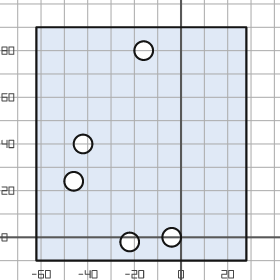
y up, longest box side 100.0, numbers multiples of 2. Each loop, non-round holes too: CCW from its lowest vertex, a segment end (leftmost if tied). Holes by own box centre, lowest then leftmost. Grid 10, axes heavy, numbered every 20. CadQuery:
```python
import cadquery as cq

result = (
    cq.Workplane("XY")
    .moveTo(-62.0, -10.0)
    .lineTo(28.0, -10.0)
    .lineTo(28.0, 90.0)
    .lineTo(-62.0, 90.0)
    .close()
    .moveTo(-22.0, -2.0)
    .circle(4.0)
    .moveTo(-4.0, 0.0)
    .circle(4.0)
    .moveTo(-46.0, 24.0)
    .circle(4.0)
    .moveTo(-42.0, 40.0)
    .circle(4.0)
    .moveTo(-16.0, 80.0)
    .circle(4.0)
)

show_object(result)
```